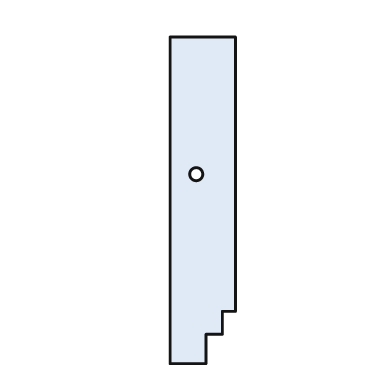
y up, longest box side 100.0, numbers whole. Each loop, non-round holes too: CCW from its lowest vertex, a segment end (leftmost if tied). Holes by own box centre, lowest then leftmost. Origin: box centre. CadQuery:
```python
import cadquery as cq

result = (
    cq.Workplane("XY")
    .moveTo(-10.0, -50.0)
    .lineTo(1.0, -50.0)
    .lineTo(1.0, -41.0)
    .lineTo(6.0, -41.0)
    .lineTo(6.0, -34.0)
    .lineTo(10.0, -34.0)
    .lineTo(10.0, 50.0)
    .lineTo(-10.0, 50.0)
    .close()
    .moveTo(-2.0, 8.0)
    .circle(2.0)
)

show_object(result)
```